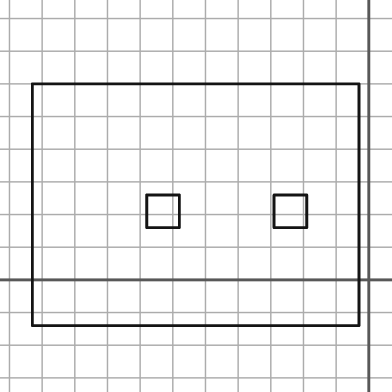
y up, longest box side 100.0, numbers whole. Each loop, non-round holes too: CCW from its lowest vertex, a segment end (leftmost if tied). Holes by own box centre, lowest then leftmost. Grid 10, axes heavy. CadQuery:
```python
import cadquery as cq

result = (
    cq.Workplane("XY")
    .moveTo(-103.0, -14.0)
    .lineTo(-3.0, -14.0)
    .lineTo(-3.0, 60.0)
    .lineTo(-103.0, 60.0)
    .close()
    .moveTo(-68.0, 16.0)
    .lineTo(-58.0, 16.0)
    .lineTo(-58.0, 26.0)
    .lineTo(-68.0, 26.0)
    .close()
    .moveTo(-29.0, 16.0)
    .lineTo(-19.0, 16.0)
    .lineTo(-19.0, 26.0)
    .lineTo(-29.0, 26.0)
    .close()
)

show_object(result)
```